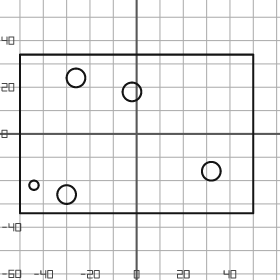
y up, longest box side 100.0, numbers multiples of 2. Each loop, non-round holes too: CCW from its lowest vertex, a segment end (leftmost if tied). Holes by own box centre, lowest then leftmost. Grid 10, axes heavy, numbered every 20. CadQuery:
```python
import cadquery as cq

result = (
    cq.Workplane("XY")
    .moveTo(-50.0, -34.0)
    .lineTo(50.0, -34.0)
    .lineTo(50.0, 34.0)
    .lineTo(-50.0, 34.0)
    .close()
    .moveTo(-30.0, -26.0)
    .circle(4.0)
    .moveTo(-44.0, -22.0)
    .circle(2.0)
    .moveTo(32.0, -16.0)
    .circle(4.0)
    .moveTo(-2.0, 18.0)
    .circle(4.0)
    .moveTo(-26.0, 24.0)
    .circle(4.0)
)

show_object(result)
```